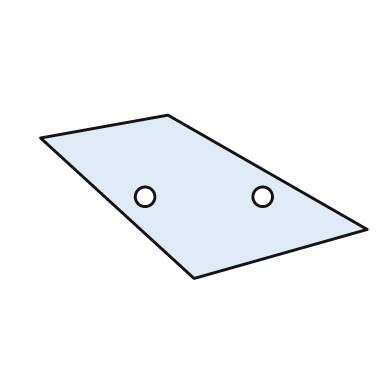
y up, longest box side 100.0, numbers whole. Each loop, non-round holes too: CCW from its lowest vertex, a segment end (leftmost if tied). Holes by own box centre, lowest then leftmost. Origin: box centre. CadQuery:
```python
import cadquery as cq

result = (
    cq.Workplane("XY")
    .moveTo(-3.0, -25.0)
    .lineTo(50.0, -10.0)
    .lineTo(-11.0, 25.0)
    .lineTo(-50.0, 18.0)
    .close()
    .moveTo(-18.0, 0.0)
    .circle(3.0)
    .moveTo(18.0, 0.0)
    .circle(3.0)
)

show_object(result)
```